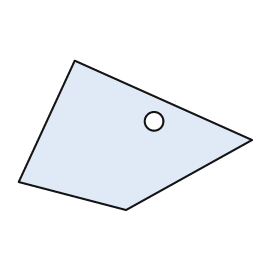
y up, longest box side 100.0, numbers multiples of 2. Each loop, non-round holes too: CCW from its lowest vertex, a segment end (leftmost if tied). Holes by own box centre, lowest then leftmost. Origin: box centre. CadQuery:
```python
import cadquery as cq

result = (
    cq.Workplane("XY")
    .moveTo(-4.0, -32.0)
    .lineTo(50.0, -2.0)
    .lineTo(-26.0, 32.0)
    .lineTo(-50.0, -20.0)
    .close()
    .moveTo(8.0, 6.0)
    .circle(4.0)
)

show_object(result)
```